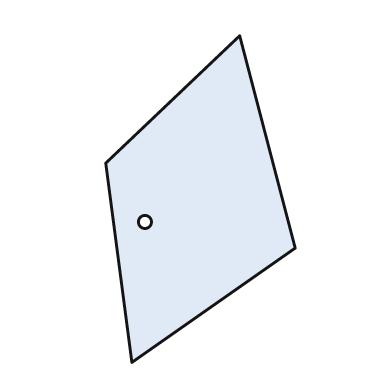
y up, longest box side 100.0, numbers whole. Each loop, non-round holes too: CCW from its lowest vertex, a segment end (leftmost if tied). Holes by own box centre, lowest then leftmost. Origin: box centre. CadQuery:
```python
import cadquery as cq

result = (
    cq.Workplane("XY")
    .moveTo(-21.0, -50.0)
    .lineTo(29.0, -15.0)
    .lineTo(12.0, 50.0)
    .lineTo(-29.0, 11.0)
    .close()
    .moveTo(-17.0, -7.0)
    .circle(2.0)
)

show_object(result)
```